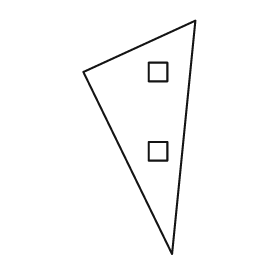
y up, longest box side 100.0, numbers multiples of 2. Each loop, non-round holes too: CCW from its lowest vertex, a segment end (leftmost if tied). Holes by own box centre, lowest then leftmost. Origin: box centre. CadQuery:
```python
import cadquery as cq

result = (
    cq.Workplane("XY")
    .moveTo(14.0, -50.0)
    .lineTo(24.0, 50.0)
    .lineTo(-24.0, 28.0)
    .close()
    .moveTo(4.0, -10.0)
    .lineTo(12.0, -10.0)
    .lineTo(12.0, -2.0)
    .lineTo(4.0, -2.0)
    .close()
    .moveTo(4.0, 24.0)
    .lineTo(12.0, 24.0)
    .lineTo(12.0, 32.0)
    .lineTo(4.0, 32.0)
    .close()
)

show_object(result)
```